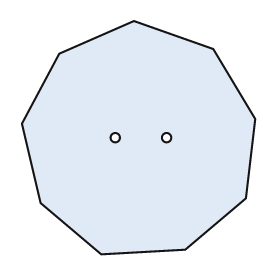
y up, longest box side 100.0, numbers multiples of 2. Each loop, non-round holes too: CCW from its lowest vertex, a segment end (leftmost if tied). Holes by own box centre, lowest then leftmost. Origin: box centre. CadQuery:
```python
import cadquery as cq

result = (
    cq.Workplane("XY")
    .moveTo(-16.0, -50.0)
    .lineTo(20.0, -48.0)
    .lineTo(46.0, -26.0)
    .lineTo(50.0, 8.0)
    .lineTo(32.0, 38.0)
    .lineTo(-2.0, 50.0)
    .lineTo(-34.0, 36.0)
    .lineTo(-50.0, 6.0)
    .lineTo(-42.0, -28.0)
    .close()
    .moveTo(-10.0, 0.0)
    .circle(2.0)
    .moveTo(12.0, 0.0)
    .circle(2.0)
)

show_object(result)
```